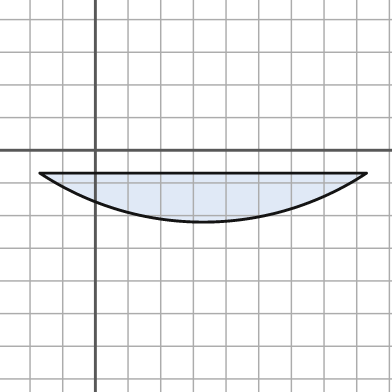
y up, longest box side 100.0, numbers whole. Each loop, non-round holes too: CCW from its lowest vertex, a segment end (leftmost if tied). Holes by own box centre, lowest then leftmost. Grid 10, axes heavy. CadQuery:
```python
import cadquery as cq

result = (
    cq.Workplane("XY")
    .moveTo(-17.0, -7.0)
    .threePointArc((33.0, -22.0), (83.0, -7.0))
    .close()
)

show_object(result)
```